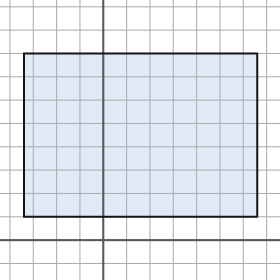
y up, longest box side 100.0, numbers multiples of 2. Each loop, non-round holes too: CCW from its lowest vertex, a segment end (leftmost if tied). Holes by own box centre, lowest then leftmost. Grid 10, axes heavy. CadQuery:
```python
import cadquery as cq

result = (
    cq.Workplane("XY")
    .moveTo(-34.0, 10.0)
    .lineTo(66.0, 10.0)
    .lineTo(66.0, 80.0)
    .lineTo(-34.0, 80.0)
    .close()
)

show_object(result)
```